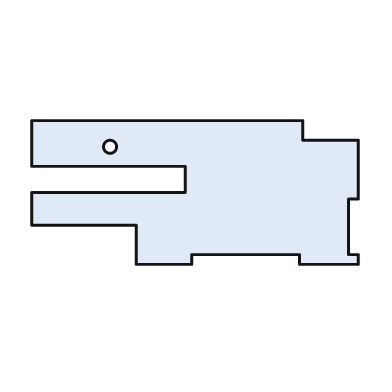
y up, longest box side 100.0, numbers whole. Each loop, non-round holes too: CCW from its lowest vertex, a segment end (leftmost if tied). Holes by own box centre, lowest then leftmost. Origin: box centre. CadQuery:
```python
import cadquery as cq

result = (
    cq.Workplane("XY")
    .moveTo(-18.0, -22.0)
    .lineTo(-1.0, -22.0)
    .lineTo(-1.0, -19.0)
    .lineTo(32.0, -19.0)
    .lineTo(32.0, -22.0)
    .lineTo(50.0, -22.0)
    .lineTo(50.0, -19.0)
    .lineTo(47.0, -19.0)
    .lineTo(47.0, -2.0)
    .lineTo(50.0, -2.0)
    .lineTo(50.0, 16.0)
    .lineTo(33.0, 16.0)
    .lineTo(33.0, 22.0)
    .lineTo(-50.0, 22.0)
    .lineTo(-50.0, 8.0)
    .lineTo(-3.0, 8.0)
    .lineTo(-3.0, 0.0)
    .lineTo(-50.0, 0.0)
    .lineTo(-50.0, -10.0)
    .lineTo(-18.0, -10.0)
    .close()
    .moveTo(-26.0, 14.0)
    .circle(2.0)
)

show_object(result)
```